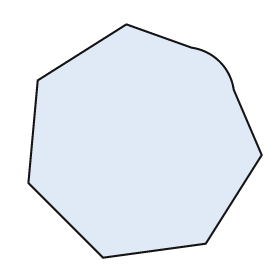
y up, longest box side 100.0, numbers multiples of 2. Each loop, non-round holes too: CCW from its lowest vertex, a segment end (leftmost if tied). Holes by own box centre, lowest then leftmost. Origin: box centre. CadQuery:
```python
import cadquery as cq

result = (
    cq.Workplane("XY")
    .moveTo(-18.0, -50.0)
    .lineTo(26.0, -44.0)
    .lineTo(50.0, -6.0)
    .lineTo(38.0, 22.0)
    .threePointArc((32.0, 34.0), (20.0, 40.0))
    .lineTo(-8.0, 50.0)
    .lineTo(-46.0, 26.0)
    .lineTo(-50.0, -18.0)
    .close()
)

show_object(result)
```